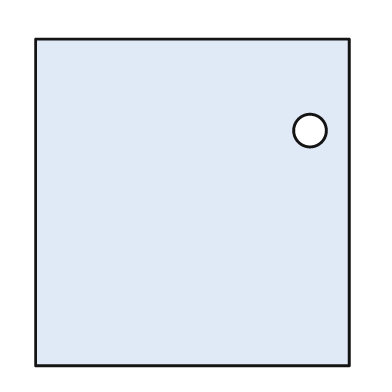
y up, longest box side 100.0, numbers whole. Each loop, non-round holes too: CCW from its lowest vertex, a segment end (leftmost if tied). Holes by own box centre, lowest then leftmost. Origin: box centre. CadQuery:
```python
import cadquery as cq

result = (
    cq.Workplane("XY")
    .moveTo(-48.0, -50.0)
    .lineTo(48.0, -50.0)
    .lineTo(48.0, 50.0)
    .lineTo(-48.0, 50.0)
    .close()
    .moveTo(36.0, 22.0)
    .circle(5.0)
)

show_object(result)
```